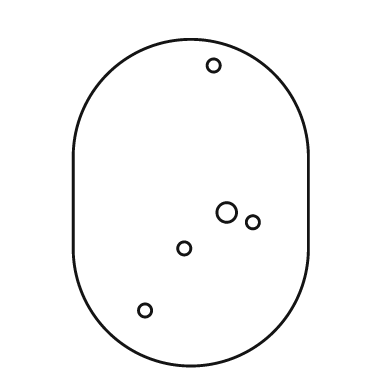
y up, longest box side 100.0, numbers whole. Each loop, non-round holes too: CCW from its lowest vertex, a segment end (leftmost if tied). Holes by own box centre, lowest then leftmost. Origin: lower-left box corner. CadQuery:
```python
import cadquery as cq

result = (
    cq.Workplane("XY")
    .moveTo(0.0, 36.0)
    .threePointArc((36.0, 0.0), (72.0, 36.0))
    .lineTo(72.0, 64.0)
    .threePointArc((36.0, 100.0), (0.0, 64.0))
    .close()
    .moveTo(22.0, 17.0)
    .circle(2.0)
    .moveTo(34.0, 36.0)
    .circle(2.0)
    .moveTo(55.0, 44.0)
    .circle(2.0)
    .moveTo(47.0, 47.0)
    .circle(3.0)
    .moveTo(43.0, 92.0)
    .circle(2.0)
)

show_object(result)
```